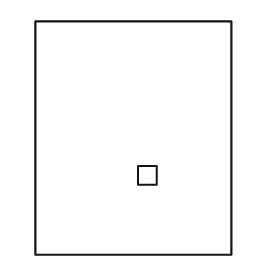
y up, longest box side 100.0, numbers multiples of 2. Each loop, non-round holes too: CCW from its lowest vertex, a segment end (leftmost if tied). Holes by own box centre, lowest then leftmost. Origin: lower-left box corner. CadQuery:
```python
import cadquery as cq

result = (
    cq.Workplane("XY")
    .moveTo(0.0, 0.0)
    .lineTo(84.0, 0.0)
    .lineTo(84.0, 100.0)
    .lineTo(0.0, 100.0)
    .close()
    .moveTo(44.0, 30.0)
    .lineTo(52.0, 30.0)
    .lineTo(52.0, 38.0)
    .lineTo(44.0, 38.0)
    .close()
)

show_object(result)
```